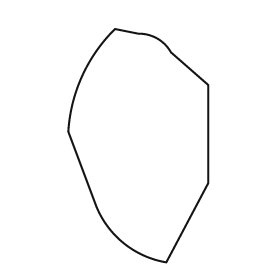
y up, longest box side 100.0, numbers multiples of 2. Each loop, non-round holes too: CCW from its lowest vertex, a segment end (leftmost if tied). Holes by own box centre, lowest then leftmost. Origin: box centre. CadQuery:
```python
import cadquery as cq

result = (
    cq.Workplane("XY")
    .moveTo(12.0, -50.0)
    .lineTo(30.0, -16.0)
    .lineTo(30.0, 26.0)
    .lineTo(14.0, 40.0)
    .threePointArc((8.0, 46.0), (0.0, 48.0))
    .lineTo(-10.0, 50.0)
    .threePointArc((-24.0, 30.0), (-30.0, 6.0))
    .lineTo(-18.0, -26.0)
    .threePointArc((-6.0, -42.0), (12.0, -50.0))
    .close()
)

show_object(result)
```